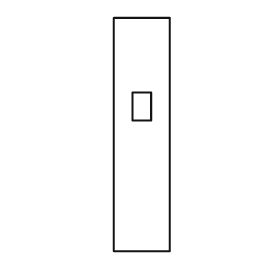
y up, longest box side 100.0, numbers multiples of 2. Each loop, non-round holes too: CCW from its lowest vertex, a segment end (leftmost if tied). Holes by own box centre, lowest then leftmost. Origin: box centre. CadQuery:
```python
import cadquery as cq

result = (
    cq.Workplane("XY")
    .moveTo(-12.0, -50.0)
    .lineTo(12.0, -50.0)
    .lineTo(12.0, 50.0)
    .lineTo(-12.0, 50.0)
    .close()
    .moveTo(-4.0, 6.0)
    .lineTo(4.0, 6.0)
    .lineTo(4.0, 18.0)
    .lineTo(-4.0, 18.0)
    .close()
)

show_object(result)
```